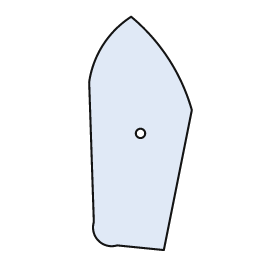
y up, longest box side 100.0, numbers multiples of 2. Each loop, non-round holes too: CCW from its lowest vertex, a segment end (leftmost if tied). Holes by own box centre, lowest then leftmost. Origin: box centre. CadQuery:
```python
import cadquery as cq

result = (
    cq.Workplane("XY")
    .moveTo(10.0, -50.0)
    .lineTo(22.0, 10.0)
    .threePointArc((12.0, 32.0), (-4.0, 50.0))
    .threePointArc((-16.0, 38.0), (-22.0, 22.0))
    .lineTo(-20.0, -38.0)
    .threePointArc((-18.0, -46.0), (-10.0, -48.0))
    .close()
    .moveTo(0.0, 0.0)
    .circle(2.0)
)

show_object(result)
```